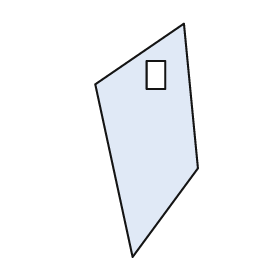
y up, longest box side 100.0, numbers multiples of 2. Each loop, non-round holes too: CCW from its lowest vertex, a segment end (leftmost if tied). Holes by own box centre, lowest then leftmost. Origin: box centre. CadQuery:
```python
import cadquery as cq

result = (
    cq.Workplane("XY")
    .moveTo(-6.0, -50.0)
    .lineTo(22.0, -12.0)
    .lineTo(16.0, 50.0)
    .lineTo(-22.0, 24.0)
    .close()
    .moveTo(0.0, 22.0)
    .lineTo(8.0, 22.0)
    .lineTo(8.0, 34.0)
    .lineTo(0.0, 34.0)
    .close()
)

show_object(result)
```